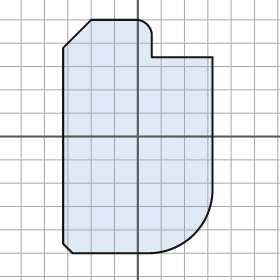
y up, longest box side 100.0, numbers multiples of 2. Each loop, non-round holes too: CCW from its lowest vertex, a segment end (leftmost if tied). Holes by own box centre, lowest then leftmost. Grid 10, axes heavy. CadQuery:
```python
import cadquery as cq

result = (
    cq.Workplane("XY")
    .moveTo(-28.0, -50.0)
    .lineTo(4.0, -50.0)
    .threePointArc((24.0, -42.0), (32.0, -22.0))
    .lineTo(32.0, 34.0)
    .lineTo(6.0, 34.0)
    .lineTo(6.0, 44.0)
    .threePointArc((4.0, 48.0), (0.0, 50.0))
    .lineTo(-20.0, 50.0)
    .lineTo(-32.0, 38.0)
    .lineTo(-32.0, -46.0)
    .close()
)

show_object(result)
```